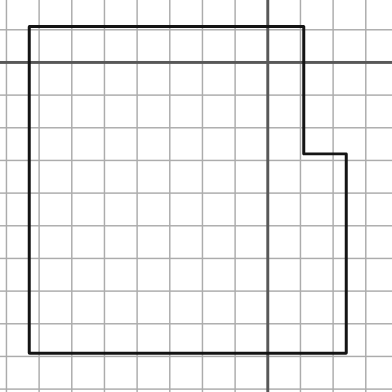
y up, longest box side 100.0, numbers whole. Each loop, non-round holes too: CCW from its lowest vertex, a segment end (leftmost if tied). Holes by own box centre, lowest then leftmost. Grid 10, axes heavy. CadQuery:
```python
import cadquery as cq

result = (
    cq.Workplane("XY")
    .moveTo(-73.0, -89.0)
    .lineTo(24.0, -89.0)
    .lineTo(24.0, -28.0)
    .lineTo(11.0, -28.0)
    .lineTo(11.0, 11.0)
    .lineTo(-73.0, 11.0)
    .close()
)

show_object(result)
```